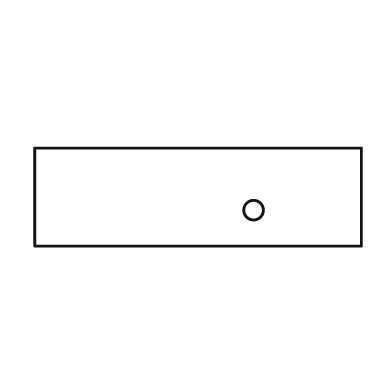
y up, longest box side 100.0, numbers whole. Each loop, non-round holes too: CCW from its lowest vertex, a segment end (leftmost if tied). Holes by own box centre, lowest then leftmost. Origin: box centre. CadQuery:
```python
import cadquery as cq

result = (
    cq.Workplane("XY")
    .moveTo(-50.0, -15.0)
    .lineTo(50.0, -15.0)
    .lineTo(50.0, 15.0)
    .lineTo(-50.0, 15.0)
    .close()
    .moveTo(17.0, -4.0)
    .circle(3.0)
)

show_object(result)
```